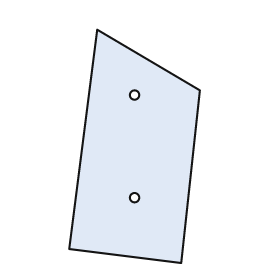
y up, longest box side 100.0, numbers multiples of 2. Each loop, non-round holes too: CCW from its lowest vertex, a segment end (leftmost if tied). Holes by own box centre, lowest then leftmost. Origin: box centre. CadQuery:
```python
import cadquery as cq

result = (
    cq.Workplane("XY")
    .moveTo(20.0, -50.0)
    .lineTo(28.0, 24.0)
    .lineTo(-16.0, 50.0)
    .lineTo(-28.0, -44.0)
    .close()
    .moveTo(0.0, -22.0)
    .circle(2.0)
    .moveTo(0.0, 22.0)
    .circle(2.0)
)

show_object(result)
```